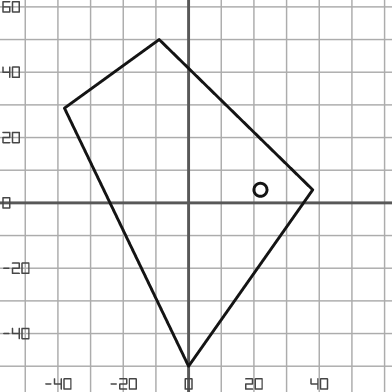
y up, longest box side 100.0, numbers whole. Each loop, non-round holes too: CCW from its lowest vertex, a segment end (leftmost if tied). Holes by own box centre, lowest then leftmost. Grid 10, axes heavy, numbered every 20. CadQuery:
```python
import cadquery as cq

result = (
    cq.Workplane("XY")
    .moveTo(0.0, -50.0)
    .lineTo(38.0, 4.0)
    .lineTo(-9.0, 50.0)
    .lineTo(-38.0, 29.0)
    .close()
    .moveTo(22.0, 4.0)
    .circle(2.0)
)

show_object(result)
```